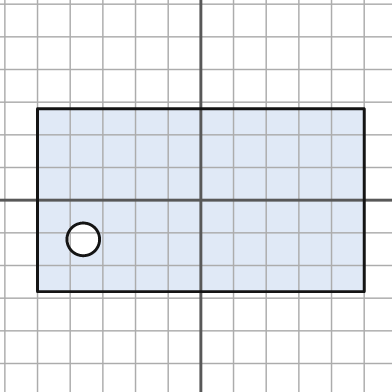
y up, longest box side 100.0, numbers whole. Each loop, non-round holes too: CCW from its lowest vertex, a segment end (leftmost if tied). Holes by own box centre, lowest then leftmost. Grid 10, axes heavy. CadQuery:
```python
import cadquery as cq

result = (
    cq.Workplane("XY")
    .moveTo(-50.0, -28.0)
    .lineTo(50.0, -28.0)
    .lineTo(50.0, 28.0)
    .lineTo(-50.0, 28.0)
    .close()
    .moveTo(-36.0, -12.0)
    .circle(5.0)
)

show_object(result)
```